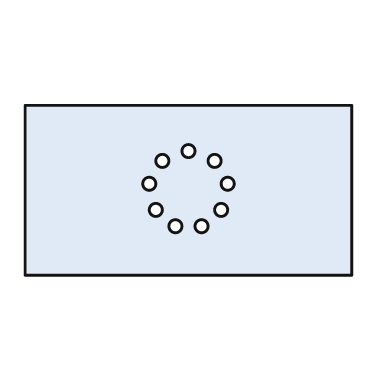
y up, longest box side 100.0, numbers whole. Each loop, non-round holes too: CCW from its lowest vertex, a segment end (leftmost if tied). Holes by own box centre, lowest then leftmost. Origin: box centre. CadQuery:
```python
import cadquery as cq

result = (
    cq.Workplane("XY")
    .moveTo(-50.0, -26.0)
    .lineTo(50.0, -26.0)
    .lineTo(50.0, 26.0)
    .lineTo(-50.0, 26.0)
    .close()
    .moveTo(-4.0, -11.0)
    .circle(2.0)
    .moveTo(4.0, -11.0)
    .circle(2.0)
    .moveTo(-10.0, -6.0)
    .circle(2.0)
    .moveTo(10.0, -6.0)
    .circle(2.0)
    .moveTo(-12.0, 2.0)
    .circle(2.0)
    .moveTo(12.0, 2.0)
    .circle(2.0)
    .moveTo(-8.0, 9.0)
    .circle(2.0)
    .moveTo(8.0, 9.0)
    .circle(2.0)
    .moveTo(0.0, 12.0)
    .circle(2.0)
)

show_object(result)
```